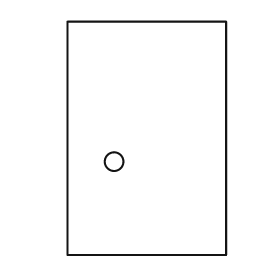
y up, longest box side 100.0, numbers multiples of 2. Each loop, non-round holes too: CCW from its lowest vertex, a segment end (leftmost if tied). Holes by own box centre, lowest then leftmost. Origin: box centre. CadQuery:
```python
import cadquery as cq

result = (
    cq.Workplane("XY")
    .moveTo(-34.0, -50.0)
    .lineTo(34.0, -50.0)
    .lineTo(34.0, 50.0)
    .lineTo(-34.0, 50.0)
    .close()
    .moveTo(-14.0, -10.0)
    .circle(4.0)
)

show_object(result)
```